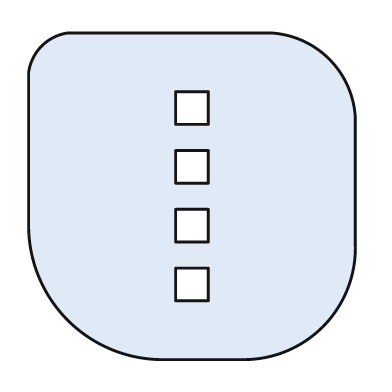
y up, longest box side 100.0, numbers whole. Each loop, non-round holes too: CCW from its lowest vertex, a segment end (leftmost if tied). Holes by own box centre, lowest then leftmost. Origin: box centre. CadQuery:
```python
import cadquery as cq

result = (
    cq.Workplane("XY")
    .moveTo(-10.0, -50.0)
    .lineTo(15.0, -50.0)
    .threePointArc((40.0, -40.0), (50.0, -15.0))
    .lineTo(50.0, 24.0)
    .threePointArc((42.0, 42.0), (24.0, 50.0))
    .lineTo(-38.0, 50.0)
    .threePointArc((-46.0, 46.0), (-50.0, 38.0))
    .lineTo(-50.0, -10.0)
    .threePointArc((-38.0, -38.0), (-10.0, -50.0))
    .close()
    .moveTo(-5.0, -32.0)
    .lineTo(5.0, -32.0)
    .lineTo(5.0, -22.0)
    .lineTo(-5.0, -22.0)
    .close()
    .moveTo(-5.0, -14.0)
    .lineTo(5.0, -14.0)
    .lineTo(5.0, -4.0)
    .lineTo(-5.0, -4.0)
    .close()
    .moveTo(-5.0, 4.0)
    .lineTo(5.0, 4.0)
    .lineTo(5.0, 14.0)
    .lineTo(-5.0, 14.0)
    .close()
    .moveTo(-5.0, 22.0)
    .lineTo(5.0, 22.0)
    .lineTo(5.0, 32.0)
    .lineTo(-5.0, 32.0)
    .close()
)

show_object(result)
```